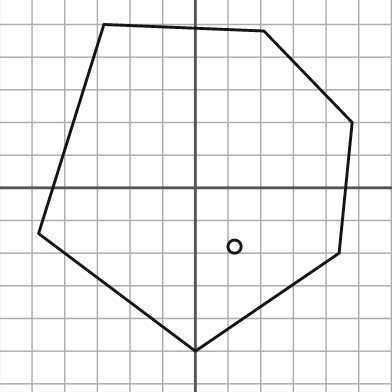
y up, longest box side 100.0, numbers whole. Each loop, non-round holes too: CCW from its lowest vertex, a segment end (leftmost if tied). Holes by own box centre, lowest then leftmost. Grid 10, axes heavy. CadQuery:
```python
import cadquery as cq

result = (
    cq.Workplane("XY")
    .moveTo(0.0, -50.0)
    .lineTo(44.0, -20.0)
    .lineTo(48.0, 20.0)
    .lineTo(21.0, 48.0)
    .lineTo(-28.0, 50.0)
    .lineTo(-48.0, -14.0)
    .close()
    .moveTo(12.0, -18.0)
    .circle(2.0)
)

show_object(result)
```